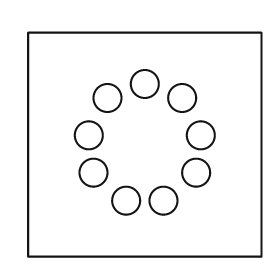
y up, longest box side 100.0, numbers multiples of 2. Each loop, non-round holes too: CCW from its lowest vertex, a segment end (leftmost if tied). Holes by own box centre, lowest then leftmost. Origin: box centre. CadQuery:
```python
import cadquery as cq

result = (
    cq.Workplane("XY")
    .moveTo(-50.0, -48.0)
    .lineTo(50.0, -48.0)
    .lineTo(50.0, 48.0)
    .lineTo(-50.0, 48.0)
    .close()
    .moveTo(-8.0, -24.0)
    .circle(6.0)
    .moveTo(8.0, -24.0)
    .circle(6.0)
    .moveTo(-22.0, -12.0)
    .circle(6.0)
    .moveTo(22.0, -12.0)
    .circle(6.0)
    .moveTo(-24.0, 4.0)
    .circle(6.0)
    .moveTo(24.0, 4.0)
    .circle(6.0)
    .moveTo(-16.0, 20.0)
    .circle(6.0)
    .moveTo(16.0, 20.0)
    .circle(6.0)
    .moveTo(0.0, 26.0)
    .circle(6.0)
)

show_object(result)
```